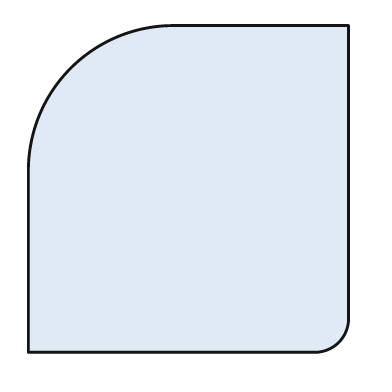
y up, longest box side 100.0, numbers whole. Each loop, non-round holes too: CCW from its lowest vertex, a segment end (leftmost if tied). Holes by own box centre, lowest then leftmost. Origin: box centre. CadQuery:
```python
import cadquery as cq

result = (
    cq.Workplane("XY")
    .moveTo(-49.0, -50.0)
    .lineTo(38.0, -50.0)
    .threePointArc((46.0, -47.0), (49.0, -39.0))
    .lineTo(49.0, 50.0)
    .lineTo(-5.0, 50.0)
    .threePointArc((-36.0, 37.0), (-49.0, 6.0))
    .close()
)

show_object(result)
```